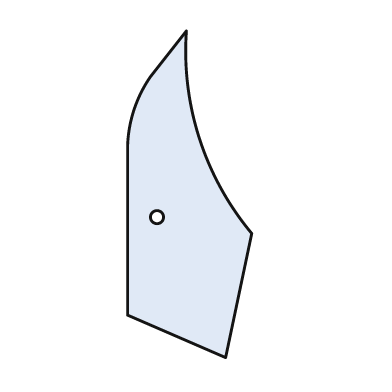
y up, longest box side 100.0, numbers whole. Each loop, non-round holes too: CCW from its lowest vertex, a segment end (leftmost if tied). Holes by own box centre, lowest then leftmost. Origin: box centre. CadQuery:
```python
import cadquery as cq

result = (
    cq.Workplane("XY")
    .moveTo(11.0, -50.0)
    .lineTo(19.0, -12.0)
    .threePointArc((3.0, 17.0), (-1.0, 50.0))
    .lineTo(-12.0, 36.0)
    .threePointArc((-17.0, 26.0), (-19.0, 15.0))
    .lineTo(-19.0, -37.0)
    .close()
    .moveTo(-10.0, -7.0)
    .circle(2.0)
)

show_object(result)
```